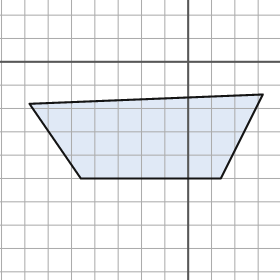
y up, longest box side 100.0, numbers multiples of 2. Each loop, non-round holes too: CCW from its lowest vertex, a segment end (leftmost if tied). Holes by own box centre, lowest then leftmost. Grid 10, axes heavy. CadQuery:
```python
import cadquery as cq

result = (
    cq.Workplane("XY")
    .moveTo(-46.0, -50.0)
    .lineTo(14.0, -50.0)
    .lineTo(32.0, -14.0)
    .lineTo(-68.0, -18.0)
    .close()
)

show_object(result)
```